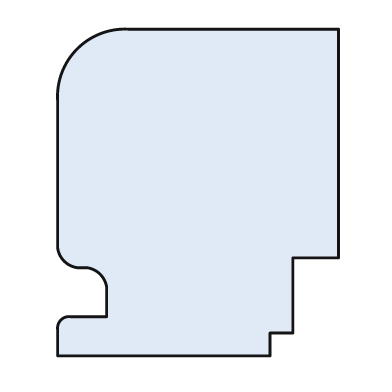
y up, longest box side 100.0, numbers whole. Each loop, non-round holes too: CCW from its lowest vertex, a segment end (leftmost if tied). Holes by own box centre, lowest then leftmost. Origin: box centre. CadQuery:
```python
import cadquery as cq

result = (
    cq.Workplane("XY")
    .moveTo(-43.0, -50.0)
    .lineTo(22.0, -50.0)
    .lineTo(22.0, -43.0)
    .lineTo(29.0, -43.0)
    .lineTo(29.0, -20.0)
    .lineTo(43.0, -20.0)
    .lineTo(43.0, 50.0)
    .lineTo(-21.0, 50.0)
    .threePointArc((-37.0, 44.0), (-43.0, 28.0))
    .lineTo(-43.0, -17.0)
    .threePointArc((-41.0, -21.0), (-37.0, -23.0))
    .lineTo(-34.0, -23.0)
    .threePointArc((-30.0, -25.0), (-28.0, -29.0))
    .lineTo(-28.0, -38.0)
    .lineTo(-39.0, -38.0)
    .threePointArc((-42.0, -39.0), (-43.0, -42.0))
    .close()
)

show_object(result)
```